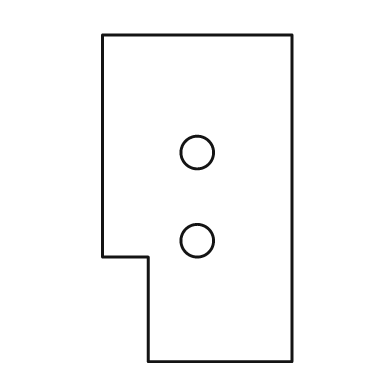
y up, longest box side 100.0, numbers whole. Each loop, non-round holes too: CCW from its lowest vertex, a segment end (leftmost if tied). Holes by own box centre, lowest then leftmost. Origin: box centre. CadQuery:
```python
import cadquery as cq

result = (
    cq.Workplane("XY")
    .moveTo(-15.0, -50.0)
    .lineTo(29.0, -50.0)
    .lineTo(29.0, 50.0)
    .lineTo(-29.0, 50.0)
    .lineTo(-29.0, -18.0)
    .lineTo(-15.0, -18.0)
    .close()
    .moveTo(0.0, -13.0)
    .circle(5.0)
    .moveTo(0.0, 14.0)
    .circle(5.0)
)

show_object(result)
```